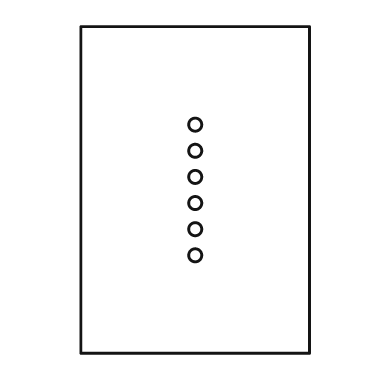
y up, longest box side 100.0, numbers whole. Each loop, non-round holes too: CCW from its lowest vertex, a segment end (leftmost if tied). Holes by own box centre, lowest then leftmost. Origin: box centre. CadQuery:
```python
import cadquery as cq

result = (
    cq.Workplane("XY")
    .moveTo(-35.0, -50.0)
    .lineTo(35.0, -50.0)
    .lineTo(35.0, 50.0)
    .lineTo(-35.0, 50.0)
    .close()
    .moveTo(0.0, -20.0)
    .circle(2.0)
    .moveTo(0.0, -12.0)
    .circle(2.0)
    .moveTo(0.0, -4.0)
    .circle(2.0)
    .moveTo(0.0, 4.0)
    .circle(2.0)
    .moveTo(0.0, 12.0)
    .circle(2.0)
    .moveTo(0.0, 20.0)
    .circle(2.0)
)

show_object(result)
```